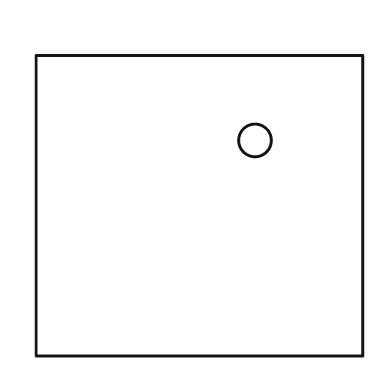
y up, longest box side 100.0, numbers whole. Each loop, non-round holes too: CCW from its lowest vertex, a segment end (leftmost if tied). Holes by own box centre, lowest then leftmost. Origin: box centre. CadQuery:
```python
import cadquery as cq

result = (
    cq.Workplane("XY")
    .moveTo(-50.0, -46.0)
    .lineTo(50.0, -46.0)
    .lineTo(50.0, 46.0)
    .lineTo(-50.0, 46.0)
    .close()
    .moveTo(17.0, 20.0)
    .circle(5.0)
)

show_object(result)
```